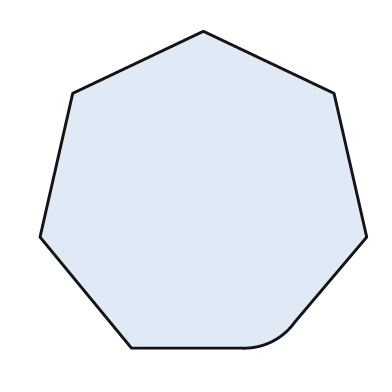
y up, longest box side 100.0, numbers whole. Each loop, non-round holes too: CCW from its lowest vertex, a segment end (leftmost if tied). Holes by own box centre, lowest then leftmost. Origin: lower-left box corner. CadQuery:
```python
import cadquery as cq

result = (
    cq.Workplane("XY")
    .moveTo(28.0, 0.0)
    .lineTo(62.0, 0.0)
    .threePointArc((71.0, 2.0), (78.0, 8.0))
    .lineTo(100.0, 34.0)
    .lineTo(90.0, 78.0)
    .lineTo(50.0, 97.0)
    .lineTo(10.0, 78.0)
    .lineTo(0.0, 34.0)
    .close()
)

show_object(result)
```